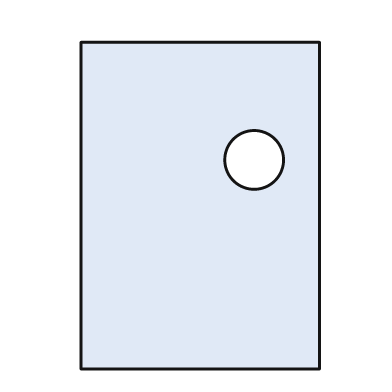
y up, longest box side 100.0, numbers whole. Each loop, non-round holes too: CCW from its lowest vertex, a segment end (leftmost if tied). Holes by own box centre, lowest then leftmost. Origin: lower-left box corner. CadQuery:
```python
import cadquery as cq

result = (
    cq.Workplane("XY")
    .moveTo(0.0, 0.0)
    .lineTo(73.0, 0.0)
    .lineTo(73.0, 100.0)
    .lineTo(0.0, 100.0)
    .close()
    .moveTo(53.0, 64.0)
    .circle(9.0)
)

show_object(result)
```